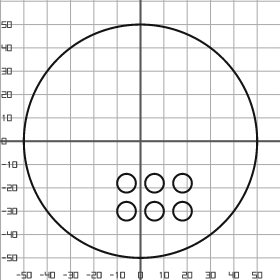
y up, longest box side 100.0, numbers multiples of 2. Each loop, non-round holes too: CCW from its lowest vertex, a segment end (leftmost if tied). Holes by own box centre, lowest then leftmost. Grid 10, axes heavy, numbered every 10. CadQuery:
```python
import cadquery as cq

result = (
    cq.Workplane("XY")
    .moveTo(0.0, 0.0)
    .circle(50.0)
    .moveTo(-6.0, -30.0)
    .circle(4.0)
    .moveTo(6.0, -30.0)
    .circle(4.0)
    .moveTo(18.0, -30.0)
    .circle(4.0)
    .moveTo(-6.0, -18.0)
    .circle(4.0)
    .moveTo(6.0, -18.0)
    .circle(4.0)
    .moveTo(18.0, -18.0)
    .circle(4.0)
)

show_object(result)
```